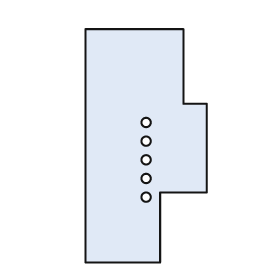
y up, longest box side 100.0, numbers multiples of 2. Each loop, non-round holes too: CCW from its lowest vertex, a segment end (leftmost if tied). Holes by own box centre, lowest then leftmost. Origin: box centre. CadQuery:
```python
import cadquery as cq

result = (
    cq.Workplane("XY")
    .moveTo(-26.0, -50.0)
    .lineTo(6.0, -50.0)
    .lineTo(6.0, -20.0)
    .lineTo(26.0, -20.0)
    .lineTo(26.0, 18.0)
    .lineTo(16.0, 18.0)
    .lineTo(16.0, 50.0)
    .lineTo(-26.0, 50.0)
    .close()
    .moveTo(0.0, -22.0)
    .circle(2.0)
    .moveTo(0.0, -14.0)
    .circle(2.0)
    .moveTo(0.0, -6.0)
    .circle(2.0)
    .moveTo(0.0, 2.0)
    .circle(2.0)
    .moveTo(0.0, 10.0)
    .circle(2.0)
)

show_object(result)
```